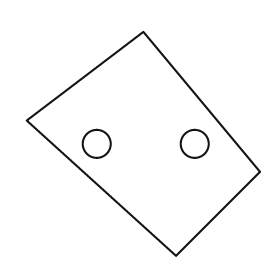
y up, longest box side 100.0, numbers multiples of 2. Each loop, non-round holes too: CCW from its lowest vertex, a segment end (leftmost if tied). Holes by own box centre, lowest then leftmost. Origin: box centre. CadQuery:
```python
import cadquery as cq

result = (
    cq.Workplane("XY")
    .moveTo(14.0, -48.0)
    .lineTo(50.0, -12.0)
    .lineTo(0.0, 48.0)
    .lineTo(-50.0, 10.0)
    .close()
    .moveTo(-20.0, 0.0)
    .circle(6.0)
    .moveTo(22.0, 0.0)
    .circle(6.0)
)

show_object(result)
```